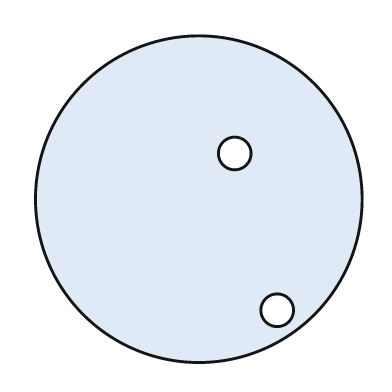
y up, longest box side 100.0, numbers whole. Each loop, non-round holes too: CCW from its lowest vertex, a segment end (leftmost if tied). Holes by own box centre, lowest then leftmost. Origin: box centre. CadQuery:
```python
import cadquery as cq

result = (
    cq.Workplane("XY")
    .moveTo(0.0, 0.0)
    .circle(50.0)
    .moveTo(24.0, -34.0)
    .circle(5.0)
    .moveTo(11.0, 14.0)
    .circle(5.0)
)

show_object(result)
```